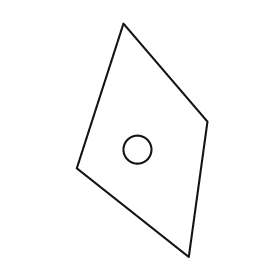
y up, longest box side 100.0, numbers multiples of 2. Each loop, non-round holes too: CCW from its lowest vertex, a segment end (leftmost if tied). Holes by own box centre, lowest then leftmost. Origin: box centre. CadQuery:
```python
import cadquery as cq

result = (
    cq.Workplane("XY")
    .moveTo(20.0, -50.0)
    .lineTo(28.0, 8.0)
    .lineTo(-8.0, 50.0)
    .lineTo(-28.0, -12.0)
    .close()
    .moveTo(-2.0, -4.0)
    .circle(6.0)
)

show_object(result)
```